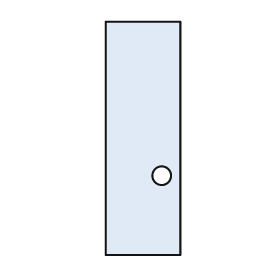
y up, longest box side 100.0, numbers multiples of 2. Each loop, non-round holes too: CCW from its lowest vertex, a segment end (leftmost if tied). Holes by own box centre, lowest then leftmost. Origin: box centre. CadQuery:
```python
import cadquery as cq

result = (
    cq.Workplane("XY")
    .moveTo(-16.0, -50.0)
    .lineTo(16.0, -50.0)
    .lineTo(16.0, 50.0)
    .lineTo(-16.0, 50.0)
    .close()
    .moveTo(8.0, -16.0)
    .circle(4.0)
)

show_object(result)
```